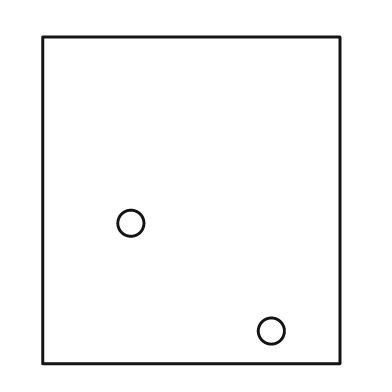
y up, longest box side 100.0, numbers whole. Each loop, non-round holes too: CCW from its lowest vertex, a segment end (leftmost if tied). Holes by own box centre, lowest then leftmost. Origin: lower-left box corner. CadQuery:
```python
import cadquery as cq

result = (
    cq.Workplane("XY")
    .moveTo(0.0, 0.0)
    .lineTo(91.0, 0.0)
    .lineTo(91.0, 100.0)
    .lineTo(0.0, 100.0)
    .close()
    .moveTo(70.0, 10.0)
    .circle(4.0)
    .moveTo(27.0, 43.0)
    .circle(4.0)
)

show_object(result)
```